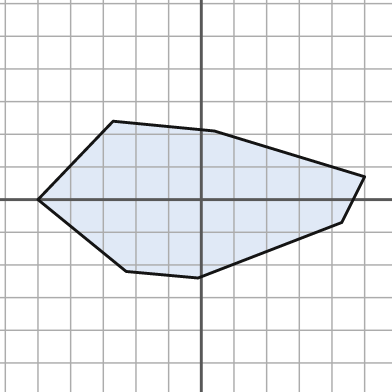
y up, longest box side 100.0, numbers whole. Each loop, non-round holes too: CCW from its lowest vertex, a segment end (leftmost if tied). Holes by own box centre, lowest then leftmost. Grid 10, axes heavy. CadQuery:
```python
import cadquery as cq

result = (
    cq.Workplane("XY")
    .moveTo(-1.0, -24.0)
    .lineTo(43.0, -7.0)
    .lineTo(50.0, 7.0)
    .lineTo(4.0, 21.0)
    .lineTo(-27.0, 24.0)
    .lineTo(-50.0, 0.0)
    .lineTo(-23.0, -22.0)
    .close()
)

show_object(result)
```